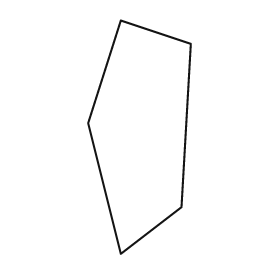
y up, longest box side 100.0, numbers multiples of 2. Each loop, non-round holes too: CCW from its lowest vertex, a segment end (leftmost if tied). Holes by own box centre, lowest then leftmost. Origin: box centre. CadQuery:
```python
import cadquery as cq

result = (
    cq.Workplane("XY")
    .moveTo(-8.0, -50.0)
    .lineTo(18.0, -30.0)
    .lineTo(22.0, 40.0)
    .lineTo(-8.0, 50.0)
    .lineTo(-22.0, 6.0)
    .close()
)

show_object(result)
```